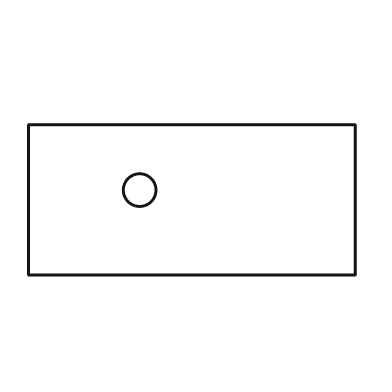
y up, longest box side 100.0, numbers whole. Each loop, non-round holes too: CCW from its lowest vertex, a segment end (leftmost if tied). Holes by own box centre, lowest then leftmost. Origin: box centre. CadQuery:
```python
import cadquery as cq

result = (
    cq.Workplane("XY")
    .moveTo(-50.0, -23.0)
    .lineTo(50.0, -23.0)
    .lineTo(50.0, 23.0)
    .lineTo(-50.0, 23.0)
    .close()
    .moveTo(-16.0, 3.0)
    .circle(5.0)
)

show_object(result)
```